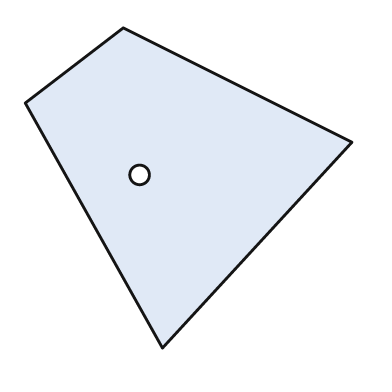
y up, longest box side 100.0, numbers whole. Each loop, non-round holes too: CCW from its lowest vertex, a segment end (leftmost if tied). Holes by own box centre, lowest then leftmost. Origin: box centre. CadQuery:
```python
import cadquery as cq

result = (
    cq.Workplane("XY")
    .moveTo(-8.0, -49.0)
    .lineTo(50.0, 14.0)
    .lineTo(-20.0, 49.0)
    .lineTo(-50.0, 26.0)
    .close()
    .moveTo(-15.0, 4.0)
    .circle(3.0)
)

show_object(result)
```